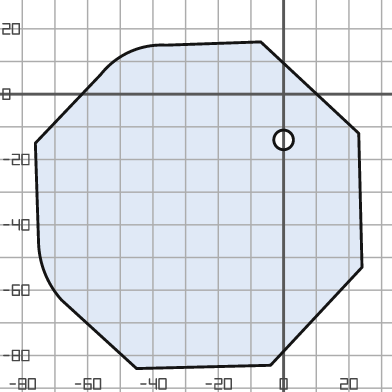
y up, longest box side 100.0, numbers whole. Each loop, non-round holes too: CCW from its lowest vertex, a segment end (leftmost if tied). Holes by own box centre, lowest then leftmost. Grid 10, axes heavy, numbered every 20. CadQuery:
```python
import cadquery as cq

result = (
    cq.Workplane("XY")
    .moveTo(-45.0, -84.0)
    .lineTo(-4.0, -83.0)
    .lineTo(24.0, -53.0)
    .lineTo(23.0, -12.0)
    .lineTo(-7.0, 16.0)
    .lineTo(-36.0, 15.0)
    .threePointArc((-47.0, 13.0), (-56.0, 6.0))
    .lineTo(-76.0, -15.0)
    .lineTo(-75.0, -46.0)
    .threePointArc((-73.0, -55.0), (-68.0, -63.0))
    .close()
    .moveTo(0.0, -14.0)
    .circle(3.0)
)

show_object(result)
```